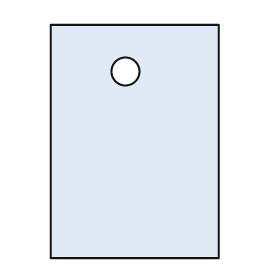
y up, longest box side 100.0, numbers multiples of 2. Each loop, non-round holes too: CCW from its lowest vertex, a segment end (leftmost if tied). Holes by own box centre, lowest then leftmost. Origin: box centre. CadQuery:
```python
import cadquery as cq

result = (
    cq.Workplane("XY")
    .moveTo(-36.0, -50.0)
    .lineTo(36.0, -50.0)
    .lineTo(36.0, 50.0)
    .lineTo(-36.0, 50.0)
    .close()
    .moveTo(-4.0, 30.0)
    .circle(6.0)
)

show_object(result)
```